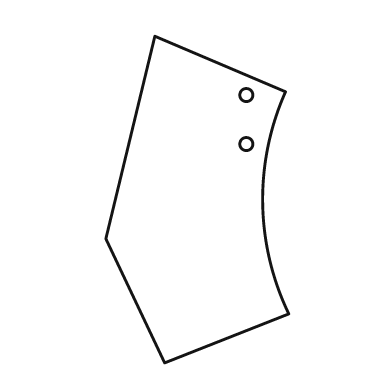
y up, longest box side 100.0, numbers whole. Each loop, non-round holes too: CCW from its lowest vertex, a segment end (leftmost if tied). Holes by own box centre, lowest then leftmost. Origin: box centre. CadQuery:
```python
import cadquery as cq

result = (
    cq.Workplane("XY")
    .moveTo(-10.0, -50.0)
    .lineTo(28.0, -35.0)
    .threePointArc((20.0, -1.0), (27.0, 33.0))
    .lineTo(-13.0, 50.0)
    .lineTo(-28.0, -12.0)
    .close()
    .moveTo(15.0, 17.0)
    .circle(2.0)
    .moveTo(15.0, 32.0)
    .circle(2.0)
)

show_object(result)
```